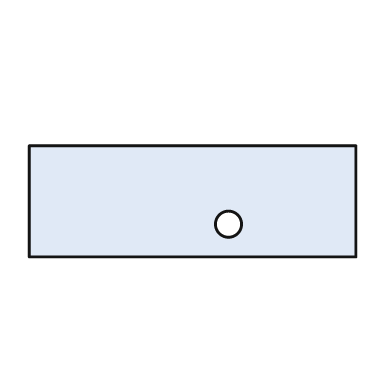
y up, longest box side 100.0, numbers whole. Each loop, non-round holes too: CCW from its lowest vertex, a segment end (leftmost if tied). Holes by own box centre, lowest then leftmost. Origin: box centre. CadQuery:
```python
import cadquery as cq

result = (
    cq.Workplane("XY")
    .moveTo(-50.0, -17.0)
    .lineTo(50.0, -17.0)
    .lineTo(50.0, 17.0)
    .lineTo(-50.0, 17.0)
    .close()
    .moveTo(11.0, -7.0)
    .circle(4.0)
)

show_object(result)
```